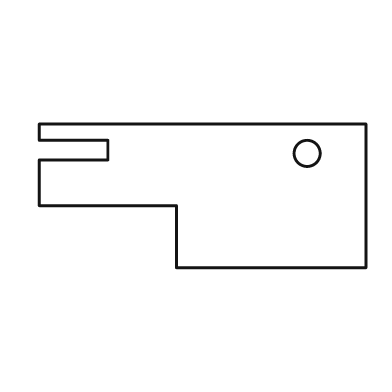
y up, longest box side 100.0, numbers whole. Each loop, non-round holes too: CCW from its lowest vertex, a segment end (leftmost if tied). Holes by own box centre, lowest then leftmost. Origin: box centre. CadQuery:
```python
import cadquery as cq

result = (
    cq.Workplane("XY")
    .moveTo(-8.0, -22.0)
    .lineTo(50.0, -22.0)
    .lineTo(50.0, 22.0)
    .lineTo(-50.0, 22.0)
    .lineTo(-50.0, 17.0)
    .lineTo(-29.0, 17.0)
    .lineTo(-29.0, 11.0)
    .lineTo(-50.0, 11.0)
    .lineTo(-50.0, -3.0)
    .lineTo(-8.0, -3.0)
    .close()
    .moveTo(32.0, 13.0)
    .circle(4.0)
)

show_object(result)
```